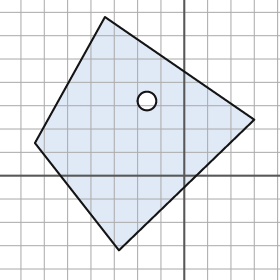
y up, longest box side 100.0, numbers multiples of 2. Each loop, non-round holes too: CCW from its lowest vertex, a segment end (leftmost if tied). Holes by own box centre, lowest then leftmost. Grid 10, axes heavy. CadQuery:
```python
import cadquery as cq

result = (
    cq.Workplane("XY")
    .moveTo(-28.0, -32.0)
    .lineTo(30.0, 24.0)
    .lineTo(-34.0, 68.0)
    .lineTo(-64.0, 14.0)
    .close()
    .moveTo(-16.0, 32.0)
    .circle(4.0)
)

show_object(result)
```